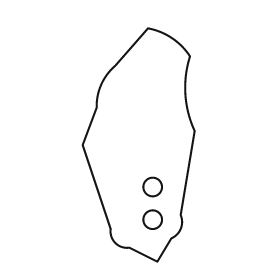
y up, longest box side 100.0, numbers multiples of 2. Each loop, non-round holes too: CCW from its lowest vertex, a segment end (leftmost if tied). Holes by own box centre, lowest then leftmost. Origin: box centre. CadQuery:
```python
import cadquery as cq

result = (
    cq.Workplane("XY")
    .moveTo(8.0, -50.0)
    .lineTo(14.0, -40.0)
    .threePointArc((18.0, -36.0), (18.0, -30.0))
    .lineTo(24.0, 6.0)
    .threePointArc((20.0, 22.0), (22.0, 38.0))
    .threePointArc((14.0, 46.0), (4.0, 50.0))
    .lineTo(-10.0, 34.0)
    .threePointArc((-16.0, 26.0), (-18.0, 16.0))
    .lineTo(-24.0, 0.0)
    .lineTo(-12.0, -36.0)
    .threePointArc((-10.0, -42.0), (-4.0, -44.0))
    .close()
    .moveTo(6.0, -32.0)
    .circle(4.0)
    .moveTo(6.0, -18.0)
    .circle(4.0)
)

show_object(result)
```